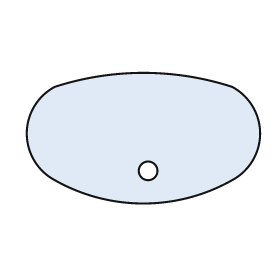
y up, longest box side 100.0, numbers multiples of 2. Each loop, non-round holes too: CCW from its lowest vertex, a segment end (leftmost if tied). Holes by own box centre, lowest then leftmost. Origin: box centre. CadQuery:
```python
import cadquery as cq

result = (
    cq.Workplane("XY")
    .moveTo(-38.0, -18.0)
    .threePointArc((0.0, -28.0), (38.0, -18.0))
    .threePointArc((50.0, 2.0), (38.0, 22.0))
    .threePointArc((0.0, 28.0), (-38.0, 22.0))
    .threePointArc((-50.0, 2.0), (-38.0, -18.0))
    .close()
    .moveTo(2.0, -14.0)
    .circle(4.0)
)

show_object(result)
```